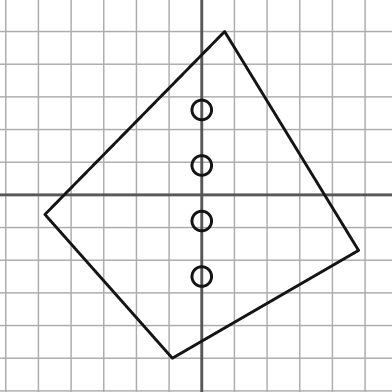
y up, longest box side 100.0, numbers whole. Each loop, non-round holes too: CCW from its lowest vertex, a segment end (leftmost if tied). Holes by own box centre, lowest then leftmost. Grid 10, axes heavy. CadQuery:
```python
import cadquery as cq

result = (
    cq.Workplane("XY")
    .moveTo(-9.0, -50.0)
    .lineTo(48.0, -17.0)
    .lineTo(7.0, 50.0)
    .lineTo(-48.0, -6.0)
    .close()
    .moveTo(0.0, -25.0)
    .circle(3.0)
    .moveTo(0.0, -8.0)
    .circle(3.0)
    .moveTo(0.0, 9.0)
    .circle(3.0)
    .moveTo(0.0, 26.0)
    .circle(3.0)
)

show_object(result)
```